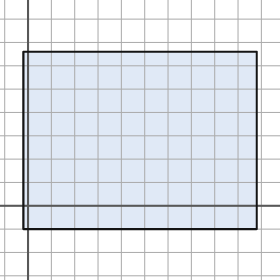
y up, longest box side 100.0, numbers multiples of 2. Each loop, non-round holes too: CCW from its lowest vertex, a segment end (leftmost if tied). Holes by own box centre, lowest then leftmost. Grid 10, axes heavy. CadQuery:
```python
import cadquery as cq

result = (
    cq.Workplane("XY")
    .moveTo(-2.0, -10.0)
    .lineTo(98.0, -10.0)
    .lineTo(98.0, 66.0)
    .lineTo(-2.0, 66.0)
    .close()
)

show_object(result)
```